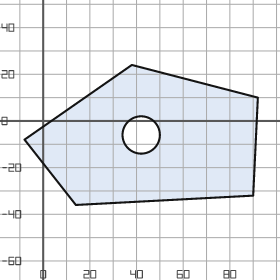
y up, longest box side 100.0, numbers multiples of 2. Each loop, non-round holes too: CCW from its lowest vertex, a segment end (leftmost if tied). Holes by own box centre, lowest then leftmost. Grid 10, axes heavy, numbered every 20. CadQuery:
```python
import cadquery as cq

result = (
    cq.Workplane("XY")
    .moveTo(14.0, -36.0)
    .lineTo(90.0, -32.0)
    .lineTo(92.0, 10.0)
    .lineTo(38.0, 24.0)
    .lineTo(-8.0, -8.0)
    .close()
    .moveTo(42.0, -6.0)
    .circle(8.0)
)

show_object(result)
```